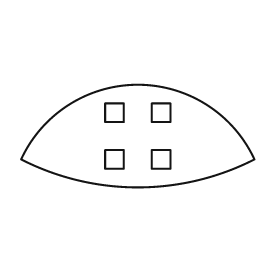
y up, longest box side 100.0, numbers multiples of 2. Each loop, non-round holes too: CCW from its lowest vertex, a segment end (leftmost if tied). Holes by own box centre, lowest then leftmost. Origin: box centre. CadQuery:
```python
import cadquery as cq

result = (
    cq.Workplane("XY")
    .moveTo(-50.0, -10.0)
    .threePointArc((0.0, -22.0), (50.0, -10.0))
    .threePointArc((0.0, 22.0), (-50.0, -10.0))
    .close()
    .moveTo(-14.0, -14.0)
    .lineTo(-6.0, -14.0)
    .lineTo(-6.0, -6.0)
    .lineTo(-14.0, -6.0)
    .close()
    .moveTo(6.0, -14.0)
    .lineTo(14.0, -14.0)
    .lineTo(14.0, -6.0)
    .lineTo(6.0, -6.0)
    .close()
    .moveTo(-14.0, 6.0)
    .lineTo(-6.0, 6.0)
    .lineTo(-6.0, 14.0)
    .lineTo(-14.0, 14.0)
    .close()
    .moveTo(6.0, 6.0)
    .lineTo(14.0, 6.0)
    .lineTo(14.0, 14.0)
    .lineTo(6.0, 14.0)
    .close()
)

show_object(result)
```